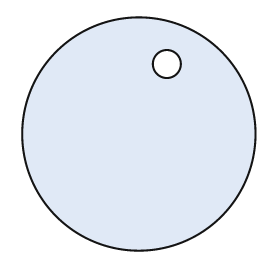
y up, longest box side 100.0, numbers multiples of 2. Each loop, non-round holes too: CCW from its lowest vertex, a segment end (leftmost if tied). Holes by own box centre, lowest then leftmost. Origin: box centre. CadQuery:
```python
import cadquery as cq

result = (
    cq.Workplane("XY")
    .moveTo(0.0, 0.0)
    .circle(50.0)
    .moveTo(12.0, 30.0)
    .circle(6.0)
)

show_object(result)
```